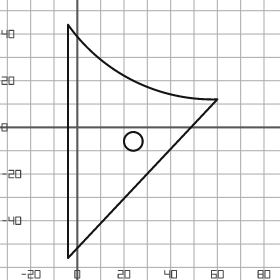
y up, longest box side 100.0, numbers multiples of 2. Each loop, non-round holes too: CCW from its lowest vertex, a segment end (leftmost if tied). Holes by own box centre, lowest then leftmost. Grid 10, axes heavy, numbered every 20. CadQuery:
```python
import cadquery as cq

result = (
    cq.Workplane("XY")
    .moveTo(-4.0, -56.0)
    .lineTo(60.0, 12.0)
    .threePointArc((24.0, 20.0), (-4.0, 44.0))
    .close()
    .moveTo(24.0, -6.0)
    .circle(4.0)
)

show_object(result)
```